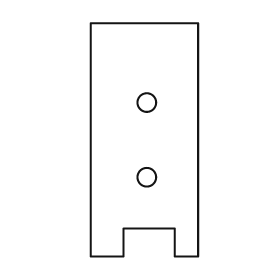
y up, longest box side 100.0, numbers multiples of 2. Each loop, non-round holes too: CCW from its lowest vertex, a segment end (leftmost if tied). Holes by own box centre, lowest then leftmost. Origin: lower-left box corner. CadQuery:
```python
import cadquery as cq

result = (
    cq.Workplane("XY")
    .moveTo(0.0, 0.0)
    .lineTo(14.0, 0.0)
    .lineTo(14.0, 12.0)
    .lineTo(36.0, 12.0)
    .lineTo(36.0, 0.0)
    .lineTo(46.0, 0.0)
    .lineTo(46.0, 100.0)
    .lineTo(0.0, 100.0)
    .close()
    .moveTo(24.0, 34.0)
    .circle(4.0)
    .moveTo(24.0, 66.0)
    .circle(4.0)
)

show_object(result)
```